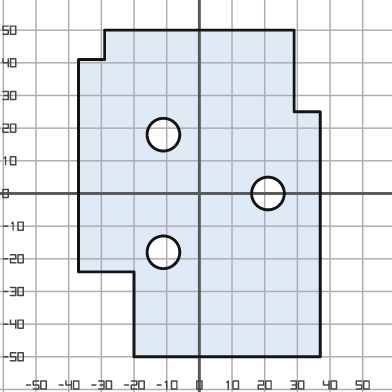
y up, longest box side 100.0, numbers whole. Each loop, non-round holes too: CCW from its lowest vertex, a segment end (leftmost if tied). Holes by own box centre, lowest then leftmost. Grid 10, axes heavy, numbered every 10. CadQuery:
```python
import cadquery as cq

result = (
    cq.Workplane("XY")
    .moveTo(-20.0, -50.0)
    .lineTo(37.0, -50.0)
    .lineTo(37.0, 25.0)
    .lineTo(29.0, 25.0)
    .lineTo(29.0, 50.0)
    .lineTo(-29.0, 50.0)
    .lineTo(-29.0, 41.0)
    .lineTo(-37.0, 41.0)
    .lineTo(-37.0, -24.0)
    .lineTo(-20.0, -24.0)
    .close()
    .moveTo(-11.0, -18.0)
    .circle(5.0)
    .moveTo(21.0, 0.0)
    .circle(5.0)
    .moveTo(-11.0, 18.0)
    .circle(5.0)
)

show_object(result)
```